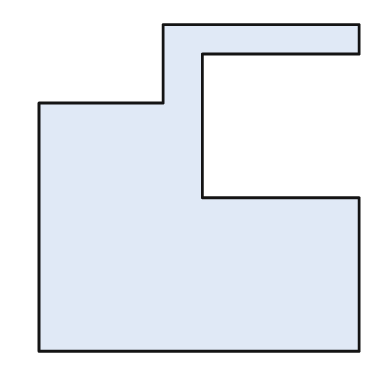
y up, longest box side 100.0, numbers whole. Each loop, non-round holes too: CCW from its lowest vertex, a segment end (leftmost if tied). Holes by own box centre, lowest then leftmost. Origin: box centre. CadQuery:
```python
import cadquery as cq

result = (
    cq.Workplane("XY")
    .moveTo(-49.0, -50.0)
    .lineTo(49.0, -50.0)
    .lineTo(49.0, -3.0)
    .lineTo(1.0, -3.0)
    .lineTo(1.0, 41.0)
    .lineTo(49.0, 41.0)
    .lineTo(49.0, 50.0)
    .lineTo(-11.0, 50.0)
    .lineTo(-11.0, 26.0)
    .lineTo(-49.0, 26.0)
    .close()
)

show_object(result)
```